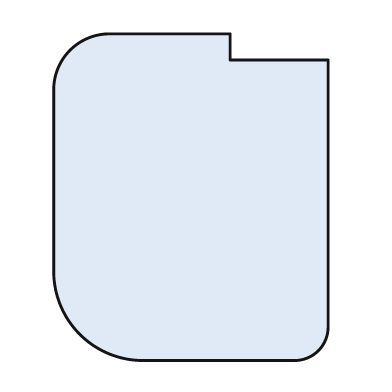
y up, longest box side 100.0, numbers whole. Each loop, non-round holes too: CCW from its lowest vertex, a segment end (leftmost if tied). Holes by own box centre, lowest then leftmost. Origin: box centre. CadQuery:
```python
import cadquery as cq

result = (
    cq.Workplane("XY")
    .moveTo(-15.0, -50.0)
    .lineTo(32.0, -50.0)
    .threePointArc((39.0, -47.0), (42.0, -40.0))
    .lineTo(42.0, 42.0)
    .lineTo(12.0, 42.0)
    .lineTo(12.0, 50.0)
    .lineTo(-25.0, 50.0)
    .threePointArc((-37.0, 45.0), (-42.0, 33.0))
    .lineTo(-42.0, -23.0)
    .threePointArc((-34.0, -42.0), (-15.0, -50.0))
    .close()
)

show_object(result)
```